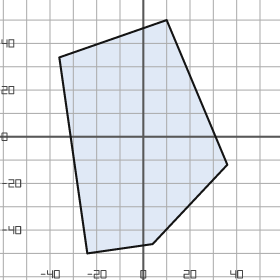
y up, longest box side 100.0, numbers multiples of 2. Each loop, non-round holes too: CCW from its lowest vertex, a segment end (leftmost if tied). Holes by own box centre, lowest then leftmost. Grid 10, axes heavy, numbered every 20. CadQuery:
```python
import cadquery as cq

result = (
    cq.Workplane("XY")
    .moveTo(-24.0, -50.0)
    .lineTo(4.0, -46.0)
    .lineTo(36.0, -12.0)
    .lineTo(10.0, 50.0)
    .lineTo(-36.0, 34.0)
    .close()
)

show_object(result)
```